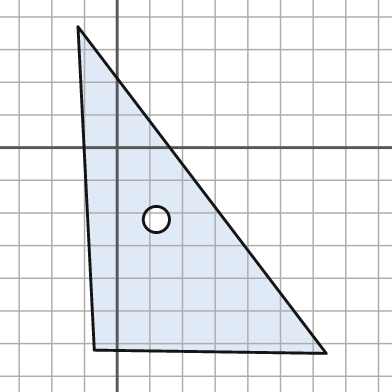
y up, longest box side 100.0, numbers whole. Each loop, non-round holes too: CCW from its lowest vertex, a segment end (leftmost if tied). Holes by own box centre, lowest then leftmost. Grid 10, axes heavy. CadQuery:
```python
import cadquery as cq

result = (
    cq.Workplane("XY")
    .moveTo(64.0, -63.0)
    .lineTo(-12.0, 37.0)
    .lineTo(-7.0, -62.0)
    .close()
    .moveTo(12.0, -22.0)
    .circle(4.0)
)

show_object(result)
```